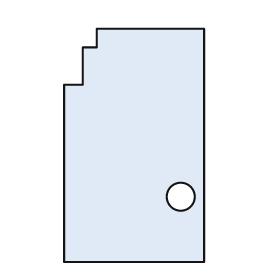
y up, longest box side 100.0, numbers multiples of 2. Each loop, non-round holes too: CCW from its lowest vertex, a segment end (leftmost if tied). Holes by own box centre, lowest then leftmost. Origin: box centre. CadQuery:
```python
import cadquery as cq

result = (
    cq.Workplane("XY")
    .moveTo(-30.0, -50.0)
    .lineTo(30.0, -50.0)
    .lineTo(30.0, 50.0)
    .lineTo(-16.0, 50.0)
    .lineTo(-16.0, 42.0)
    .lineTo(-22.0, 42.0)
    .lineTo(-22.0, 26.0)
    .lineTo(-30.0, 26.0)
    .close()
    .moveTo(20.0, -22.0)
    .circle(6.0)
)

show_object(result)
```